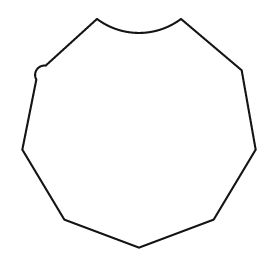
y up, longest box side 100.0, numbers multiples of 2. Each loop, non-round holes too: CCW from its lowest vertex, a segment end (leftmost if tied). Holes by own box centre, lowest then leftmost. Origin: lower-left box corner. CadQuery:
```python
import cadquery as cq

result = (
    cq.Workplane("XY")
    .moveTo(50.0, 0.0)
    .lineTo(82.0, 12.0)
    .lineTo(100.0, 42.0)
    .lineTo(94.0, 76.0)
    .lineTo(68.0, 98.0)
    .threePointArc((50.0, 92.0), (32.0, 98.0))
    .lineTo(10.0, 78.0)
    .threePointArc((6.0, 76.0), (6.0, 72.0))
    .lineTo(0.0, 42.0)
    .lineTo(18.0, 12.0)
    .close()
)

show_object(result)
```